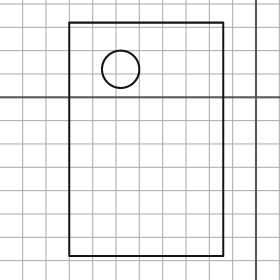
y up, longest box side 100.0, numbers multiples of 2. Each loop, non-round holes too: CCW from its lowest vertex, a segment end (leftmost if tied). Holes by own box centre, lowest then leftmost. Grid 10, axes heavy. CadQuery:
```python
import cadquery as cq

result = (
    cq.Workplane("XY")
    .moveTo(-80.0, -68.0)
    .lineTo(-14.0, -68.0)
    .lineTo(-14.0, 32.0)
    .lineTo(-80.0, 32.0)
    .close()
    .moveTo(-58.0, 12.0)
    .circle(8.0)
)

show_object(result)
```